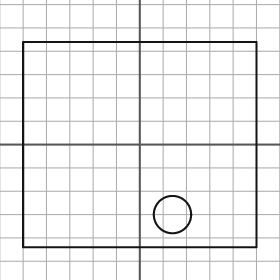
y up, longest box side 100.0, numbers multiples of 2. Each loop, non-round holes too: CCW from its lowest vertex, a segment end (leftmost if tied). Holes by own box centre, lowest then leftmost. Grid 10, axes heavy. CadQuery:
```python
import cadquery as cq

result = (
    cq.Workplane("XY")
    .moveTo(-50.0, -44.0)
    .lineTo(50.0, -44.0)
    .lineTo(50.0, 44.0)
    .lineTo(-50.0, 44.0)
    .close()
    .moveTo(14.0, -30.0)
    .circle(8.0)
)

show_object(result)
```